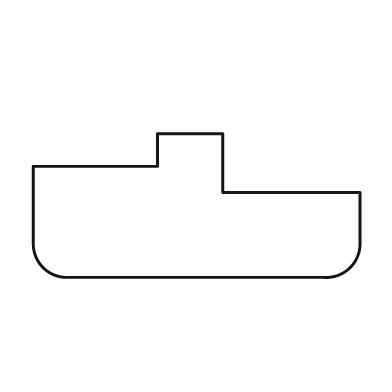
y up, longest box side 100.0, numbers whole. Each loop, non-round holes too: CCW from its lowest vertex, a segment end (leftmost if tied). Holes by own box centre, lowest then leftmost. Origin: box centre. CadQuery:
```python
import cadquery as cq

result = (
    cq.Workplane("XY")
    .moveTo(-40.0, -22.0)
    .lineTo(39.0, -22.0)
    .threePointArc((47.0, -19.0), (50.0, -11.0))
    .lineTo(50.0, 4.0)
    .lineTo(8.0, 4.0)
    .lineTo(8.0, 22.0)
    .lineTo(-12.0, 22.0)
    .lineTo(-12.0, 12.0)
    .lineTo(-50.0, 12.0)
    .lineTo(-50.0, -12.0)
    .threePointArc((-47.0, -19.0), (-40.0, -22.0))
    .close()
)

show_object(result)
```